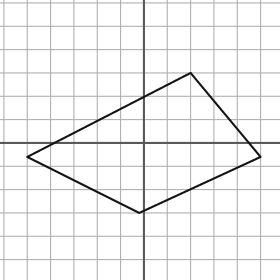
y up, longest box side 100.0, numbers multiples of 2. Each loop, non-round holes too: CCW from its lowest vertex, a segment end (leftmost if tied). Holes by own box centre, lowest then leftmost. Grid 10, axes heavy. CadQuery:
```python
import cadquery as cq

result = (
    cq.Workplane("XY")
    .moveTo(-2.0, -30.0)
    .lineTo(50.0, -6.0)
    .lineTo(20.0, 30.0)
    .lineTo(-50.0, -6.0)
    .close()
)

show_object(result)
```